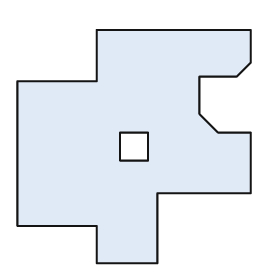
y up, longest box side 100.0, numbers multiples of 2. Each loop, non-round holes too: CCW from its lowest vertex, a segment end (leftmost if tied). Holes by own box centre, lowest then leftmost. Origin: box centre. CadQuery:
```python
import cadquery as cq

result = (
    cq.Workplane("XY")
    .moveTo(-16.0, -50.0)
    .lineTo(10.0, -50.0)
    .lineTo(10.0, -20.0)
    .lineTo(50.0, -20.0)
    .lineTo(50.0, 6.0)
    .lineTo(36.0, 6.0)
    .lineTo(28.0, 14.0)
    .lineTo(28.0, 30.0)
    .lineTo(44.0, 30.0)
    .lineTo(50.0, 36.0)
    .lineTo(50.0, 50.0)
    .lineTo(-16.0, 50.0)
    .lineTo(-16.0, 28.0)
    .lineTo(-50.0, 28.0)
    .lineTo(-50.0, -34.0)
    .lineTo(-16.0, -34.0)
    .close()
    .moveTo(-6.0, -6.0)
    .lineTo(6.0, -6.0)
    .lineTo(6.0, 6.0)
    .lineTo(-6.0, 6.0)
    .close()
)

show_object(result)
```